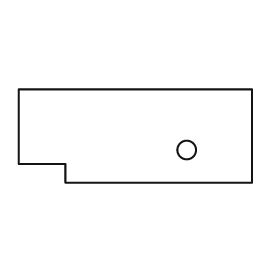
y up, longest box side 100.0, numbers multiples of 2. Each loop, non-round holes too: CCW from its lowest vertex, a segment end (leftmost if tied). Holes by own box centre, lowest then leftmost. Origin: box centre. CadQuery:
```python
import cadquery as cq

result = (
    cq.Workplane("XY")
    .moveTo(-30.0, -20.0)
    .lineTo(50.0, -20.0)
    .lineTo(50.0, 20.0)
    .lineTo(-50.0, 20.0)
    .lineTo(-50.0, -12.0)
    .lineTo(-30.0, -12.0)
    .close()
    .moveTo(22.0, -6.0)
    .circle(4.0)
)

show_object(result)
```